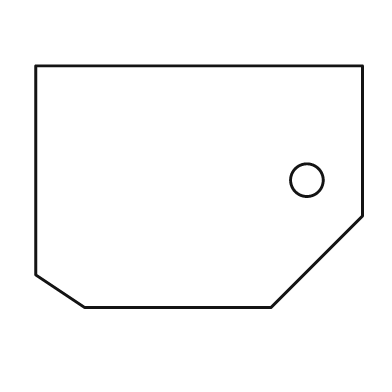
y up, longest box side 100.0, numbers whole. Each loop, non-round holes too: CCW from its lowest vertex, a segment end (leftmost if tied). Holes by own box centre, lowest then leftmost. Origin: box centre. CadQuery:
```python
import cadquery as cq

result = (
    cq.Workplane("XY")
    .moveTo(-35.0, -37.0)
    .lineTo(22.0, -37.0)
    .lineTo(50.0, -9.0)
    .lineTo(50.0, 37.0)
    .lineTo(-50.0, 37.0)
    .lineTo(-50.0, -27.0)
    .close()
    .moveTo(33.0, 2.0)
    .circle(5.0)
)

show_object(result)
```